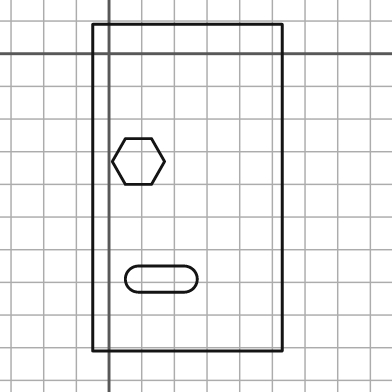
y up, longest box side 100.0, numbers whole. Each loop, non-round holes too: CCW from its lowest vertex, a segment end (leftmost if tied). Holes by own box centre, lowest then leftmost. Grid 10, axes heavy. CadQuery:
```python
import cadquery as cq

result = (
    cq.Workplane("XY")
    .moveTo(-5.0, -91.0)
    .lineTo(53.0, -91.0)
    .lineTo(53.0, 9.0)
    .lineTo(-5.0, 9.0)
    .close()
    .moveTo(9.0, -73.0)
    .lineTo(23.0, -73.0)
    .threePointArc((27.0, -69.0), (23.0, -65.0))
    .lineTo(9.0, -65.0)
    .threePointArc((5.0, -69.0), (9.0, -73.0))
    .close()
    .moveTo(5.0, -40.0)
    .lineTo(13.0, -40.0)
    .lineTo(17.0, -33.0)
    .lineTo(13.0, -26.0)
    .lineTo(5.0, -26.0)
    .lineTo(1.0, -33.0)
    .close()
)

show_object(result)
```